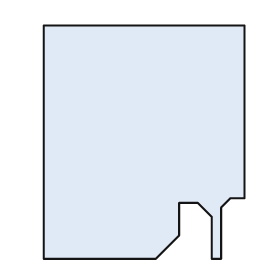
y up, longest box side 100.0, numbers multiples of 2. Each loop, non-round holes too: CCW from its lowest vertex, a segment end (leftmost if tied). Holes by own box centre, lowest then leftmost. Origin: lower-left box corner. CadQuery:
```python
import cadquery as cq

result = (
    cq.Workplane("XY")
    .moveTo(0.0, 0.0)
    .lineTo(48.0, 0.0)
    .lineTo(58.0, 10.0)
    .lineTo(58.0, 24.0)
    .lineTo(66.0, 24.0)
    .lineTo(72.0, 18.0)
    .lineTo(72.0, 0.0)
    .lineTo(76.0, 0.0)
    .lineTo(76.0, 22.0)
    .lineTo(80.0, 26.0)
    .lineTo(86.0, 26.0)
    .lineTo(86.0, 100.0)
    .lineTo(0.0, 100.0)
    .close()
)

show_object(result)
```